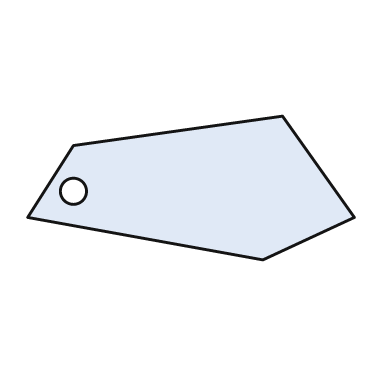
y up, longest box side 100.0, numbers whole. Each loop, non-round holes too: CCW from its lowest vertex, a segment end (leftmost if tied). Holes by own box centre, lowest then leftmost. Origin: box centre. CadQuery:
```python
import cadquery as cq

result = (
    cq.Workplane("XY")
    .moveTo(22.0, -22.0)
    .lineTo(50.0, -9.0)
    .lineTo(28.0, 22.0)
    .lineTo(-36.0, 13.0)
    .lineTo(-50.0, -9.0)
    .close()
    .moveTo(-36.0, -1.0)
    .circle(4.0)
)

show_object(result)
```